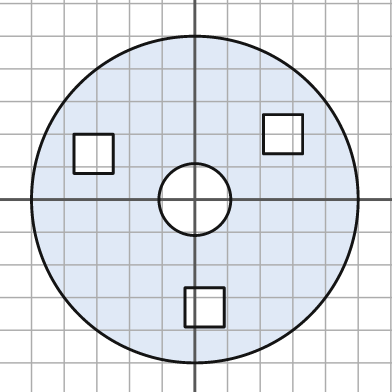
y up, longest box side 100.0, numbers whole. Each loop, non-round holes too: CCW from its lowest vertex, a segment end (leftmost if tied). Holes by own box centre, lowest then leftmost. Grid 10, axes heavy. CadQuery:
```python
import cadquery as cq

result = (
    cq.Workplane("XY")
    .moveTo(0.0, 0.0)
    .circle(50.0)
    .moveTo(-3.0, -39.0)
    .lineTo(9.0, -39.0)
    .lineTo(9.0, -27.0)
    .lineTo(-3.0, -27.0)
    .close()
    .moveTo(0.0, 0.0)
    .circle(11.0)
    .moveTo(-37.0, 8.0)
    .lineTo(-25.0, 8.0)
    .lineTo(-25.0, 20.0)
    .lineTo(-37.0, 20.0)
    .close()
    .moveTo(21.0, 14.0)
    .lineTo(33.0, 14.0)
    .lineTo(33.0, 26.0)
    .lineTo(21.0, 26.0)
    .close()
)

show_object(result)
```